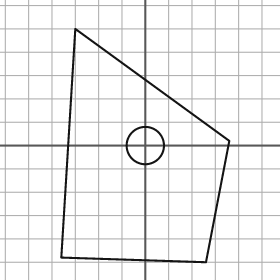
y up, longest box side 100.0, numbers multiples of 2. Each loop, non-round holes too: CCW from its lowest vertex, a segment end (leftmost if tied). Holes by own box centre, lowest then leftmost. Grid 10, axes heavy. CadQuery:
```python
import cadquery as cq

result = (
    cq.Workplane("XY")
    .moveTo(26.0, -50.0)
    .lineTo(36.0, 2.0)
    .lineTo(-30.0, 50.0)
    .lineTo(-36.0, -48.0)
    .close()
    .moveTo(0.0, 0.0)
    .circle(8.0)
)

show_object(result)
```